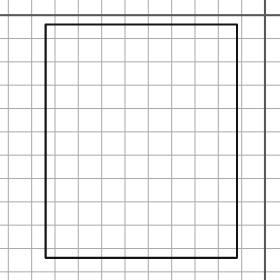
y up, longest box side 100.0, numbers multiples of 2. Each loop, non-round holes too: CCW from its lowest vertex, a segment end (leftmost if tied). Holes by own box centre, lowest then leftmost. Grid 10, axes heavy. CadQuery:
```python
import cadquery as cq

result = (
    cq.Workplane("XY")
    .moveTo(-94.0, -104.0)
    .lineTo(-12.0, -104.0)
    .lineTo(-12.0, -4.0)
    .lineTo(-94.0, -4.0)
    .close()
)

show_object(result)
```